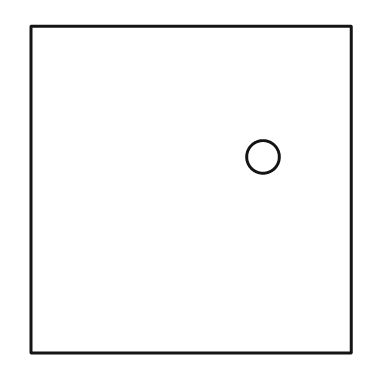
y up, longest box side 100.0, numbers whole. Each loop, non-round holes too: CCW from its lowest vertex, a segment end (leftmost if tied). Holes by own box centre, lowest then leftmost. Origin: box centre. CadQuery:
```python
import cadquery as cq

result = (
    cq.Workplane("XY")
    .moveTo(-49.0, -50.0)
    .lineTo(49.0, -50.0)
    .lineTo(49.0, 50.0)
    .lineTo(-49.0, 50.0)
    .close()
    .moveTo(22.0, 10.0)
    .circle(5.0)
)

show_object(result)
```